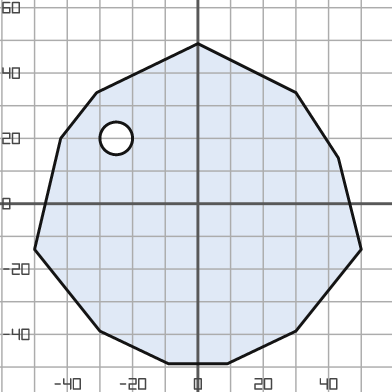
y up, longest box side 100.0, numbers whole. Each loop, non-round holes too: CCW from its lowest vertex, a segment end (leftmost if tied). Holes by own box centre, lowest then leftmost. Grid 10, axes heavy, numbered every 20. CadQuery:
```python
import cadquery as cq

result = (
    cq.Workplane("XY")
    .moveTo(-9.0, -49.0)
    .lineTo(9.0, -49.0)
    .lineTo(30.0, -39.0)
    .lineTo(50.0, -14.0)
    .lineTo(43.0, 14.0)
    .lineTo(30.0, 34.0)
    .lineTo(0.0, 49.0)
    .lineTo(-31.0, 34.0)
    .lineTo(-42.0, 20.0)
    .lineTo(-50.0, -14.0)
    .lineTo(-30.0, -39.0)
    .close()
    .moveTo(-25.0, 20.0)
    .circle(5.0)
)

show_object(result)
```